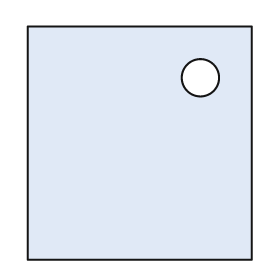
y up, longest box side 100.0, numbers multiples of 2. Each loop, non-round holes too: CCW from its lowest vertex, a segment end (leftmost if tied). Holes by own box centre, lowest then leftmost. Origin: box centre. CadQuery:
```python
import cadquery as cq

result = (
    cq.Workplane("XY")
    .moveTo(-48.0, -50.0)
    .lineTo(48.0, -50.0)
    .lineTo(48.0, 50.0)
    .lineTo(-48.0, 50.0)
    .close()
    .moveTo(26.0, 28.0)
    .circle(8.0)
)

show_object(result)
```